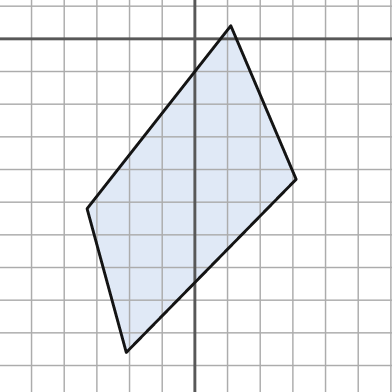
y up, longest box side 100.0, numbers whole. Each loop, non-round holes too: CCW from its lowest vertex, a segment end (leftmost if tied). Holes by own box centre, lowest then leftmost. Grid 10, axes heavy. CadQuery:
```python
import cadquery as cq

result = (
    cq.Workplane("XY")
    .moveTo(-21.0, -96.0)
    .lineTo(31.0, -43.0)
    .lineTo(11.0, 4.0)
    .lineTo(-33.0, -52.0)
    .close()
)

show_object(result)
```